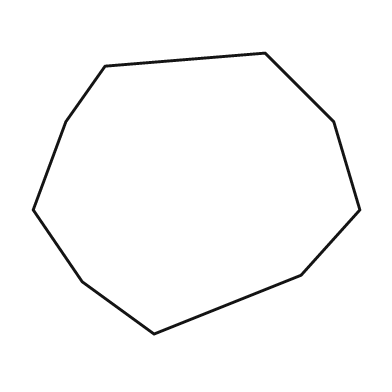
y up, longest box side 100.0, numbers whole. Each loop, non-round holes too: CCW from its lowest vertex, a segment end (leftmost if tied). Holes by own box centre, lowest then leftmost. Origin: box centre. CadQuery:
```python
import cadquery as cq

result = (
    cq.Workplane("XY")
    .moveTo(-13.0, -43.0)
    .lineTo(32.0, -25.0)
    .lineTo(50.0, -5.0)
    .lineTo(42.0, 22.0)
    .lineTo(21.0, 43.0)
    .lineTo(-28.0, 39.0)
    .lineTo(-40.0, 22.0)
    .lineTo(-50.0, -5.0)
    .lineTo(-35.0, -27.0)
    .close()
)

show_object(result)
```